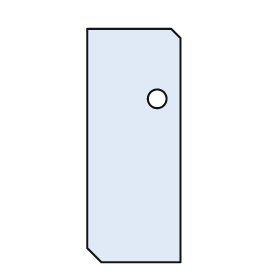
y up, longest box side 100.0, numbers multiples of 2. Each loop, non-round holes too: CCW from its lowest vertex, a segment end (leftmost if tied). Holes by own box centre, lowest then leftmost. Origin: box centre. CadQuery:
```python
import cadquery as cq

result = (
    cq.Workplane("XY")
    .moveTo(-14.0, -50.0)
    .lineTo(20.0, -50.0)
    .lineTo(20.0, 46.0)
    .lineTo(16.0, 50.0)
    .lineTo(-20.0, 50.0)
    .lineTo(-20.0, -44.0)
    .close()
    .moveTo(10.0, 20.0)
    .circle(4.0)
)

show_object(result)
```